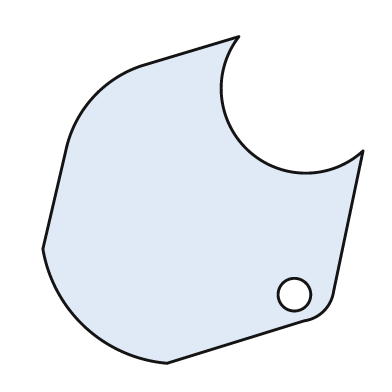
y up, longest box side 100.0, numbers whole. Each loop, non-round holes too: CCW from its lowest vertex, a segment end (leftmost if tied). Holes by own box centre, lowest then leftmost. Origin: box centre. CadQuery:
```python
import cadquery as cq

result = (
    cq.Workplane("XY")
    .moveTo(-11.0, -50.0)
    .lineTo(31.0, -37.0)
    .threePointArc((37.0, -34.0), (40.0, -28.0))
    .lineTo(49.0, 15.0)
    .threePointArc((14.0, 15.0), (11.0, 50.0))
    .lineTo(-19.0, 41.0)
    .threePointArc((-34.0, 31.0), (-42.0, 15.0))
    .lineTo(-49.0, -15.0)
    .threePointArc((-36.0, -39.0), (-11.0, -50.0))
    .close()
    .moveTo(28.0, -29.0)
    .circle(5.0)
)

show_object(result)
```